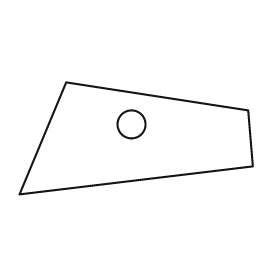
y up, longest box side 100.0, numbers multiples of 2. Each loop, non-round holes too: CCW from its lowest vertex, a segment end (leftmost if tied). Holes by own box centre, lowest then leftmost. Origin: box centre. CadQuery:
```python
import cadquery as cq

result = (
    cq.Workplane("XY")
    .moveTo(-50.0, -24.0)
    .lineTo(50.0, -12.0)
    .lineTo(48.0, 12.0)
    .lineTo(-30.0, 24.0)
    .close()
    .moveTo(-2.0, 6.0)
    .circle(6.0)
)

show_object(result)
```